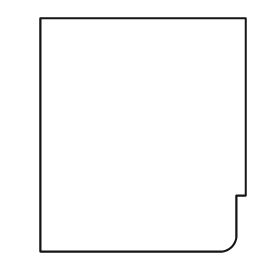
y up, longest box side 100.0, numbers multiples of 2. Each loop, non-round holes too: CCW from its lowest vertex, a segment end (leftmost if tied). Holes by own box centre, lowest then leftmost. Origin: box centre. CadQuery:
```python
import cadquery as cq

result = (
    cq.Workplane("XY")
    .moveTo(-44.0, -50.0)
    .lineTo(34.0, -50.0)
    .threePointArc((38.0, -48.0), (40.0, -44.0))
    .lineTo(40.0, -26.0)
    .lineTo(44.0, -26.0)
    .lineTo(44.0, 50.0)
    .lineTo(-44.0, 50.0)
    .close()
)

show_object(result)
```